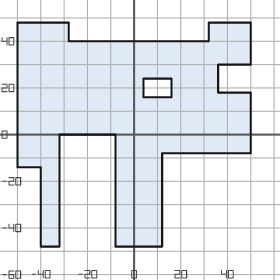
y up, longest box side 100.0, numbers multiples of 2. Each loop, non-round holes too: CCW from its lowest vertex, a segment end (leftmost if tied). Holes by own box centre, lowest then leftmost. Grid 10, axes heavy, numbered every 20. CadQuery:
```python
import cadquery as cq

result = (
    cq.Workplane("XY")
    .moveTo(-40.0, -48.0)
    .lineTo(-32.0, -48.0)
    .lineTo(-32.0, 0.0)
    .lineTo(-8.0, 0.0)
    .lineTo(-8.0, -48.0)
    .lineTo(12.0, -48.0)
    .lineTo(12.0, -8.0)
    .lineTo(50.0, -8.0)
    .lineTo(50.0, 18.0)
    .lineTo(36.0, 18.0)
    .lineTo(36.0, 30.0)
    .lineTo(50.0, 30.0)
    .lineTo(50.0, 48.0)
    .lineTo(32.0, 48.0)
    .lineTo(32.0, 40.0)
    .lineTo(-28.0, 40.0)
    .lineTo(-28.0, 48.0)
    .lineTo(-50.0, 48.0)
    .lineTo(-50.0, -14.0)
    .lineTo(-40.0, -14.0)
    .close()
    .moveTo(4.0, 16.0)
    .lineTo(16.0, 16.0)
    .lineTo(16.0, 24.0)
    .lineTo(4.0, 24.0)
    .close()
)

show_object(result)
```